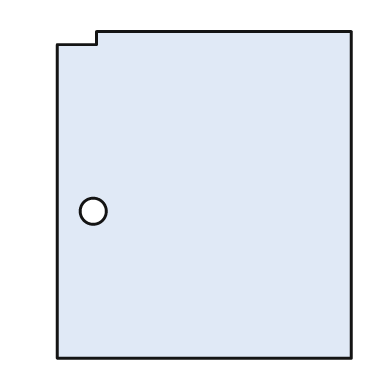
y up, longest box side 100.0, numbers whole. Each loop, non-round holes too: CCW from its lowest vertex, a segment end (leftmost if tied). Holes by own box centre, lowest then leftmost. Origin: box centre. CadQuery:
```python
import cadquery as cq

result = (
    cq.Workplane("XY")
    .moveTo(-45.0, -50.0)
    .lineTo(45.0, -50.0)
    .lineTo(45.0, 50.0)
    .lineTo(-33.0, 50.0)
    .lineTo(-33.0, 46.0)
    .lineTo(-45.0, 46.0)
    .close()
    .moveTo(-34.0, -5.0)
    .circle(4.0)
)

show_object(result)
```